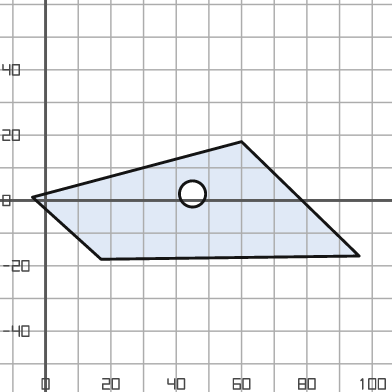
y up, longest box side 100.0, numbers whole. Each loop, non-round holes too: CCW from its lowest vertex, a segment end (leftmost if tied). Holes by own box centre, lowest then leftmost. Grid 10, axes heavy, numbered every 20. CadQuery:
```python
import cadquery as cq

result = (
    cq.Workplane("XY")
    .moveTo(17.0, -18.0)
    .lineTo(96.0, -17.0)
    .lineTo(60.0, 18.0)
    .lineTo(-4.0, 1.0)
    .close()
    .moveTo(45.0, 2.0)
    .circle(4.0)
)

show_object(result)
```